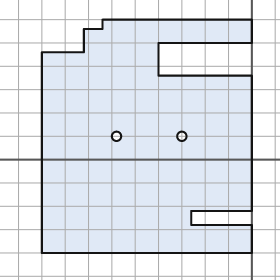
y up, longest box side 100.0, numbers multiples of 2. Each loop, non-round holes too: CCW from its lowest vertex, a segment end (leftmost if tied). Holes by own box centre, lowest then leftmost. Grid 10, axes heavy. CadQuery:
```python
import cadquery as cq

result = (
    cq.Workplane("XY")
    .moveTo(-90.0, -40.0)
    .lineTo(0.0, -40.0)
    .lineTo(0.0, -28.0)
    .lineTo(-26.0, -28.0)
    .lineTo(-26.0, -22.0)
    .lineTo(0.0, -22.0)
    .lineTo(0.0, 36.0)
    .lineTo(-40.0, 36.0)
    .lineTo(-40.0, 50.0)
    .lineTo(0.0, 50.0)
    .lineTo(0.0, 60.0)
    .lineTo(-64.0, 60.0)
    .lineTo(-64.0, 56.0)
    .lineTo(-72.0, 56.0)
    .lineTo(-72.0, 46.0)
    .lineTo(-90.0, 46.0)
    .close()
    .moveTo(-58.0, 10.0)
    .circle(2.0)
    .moveTo(-30.0, 10.0)
    .circle(2.0)
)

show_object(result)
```